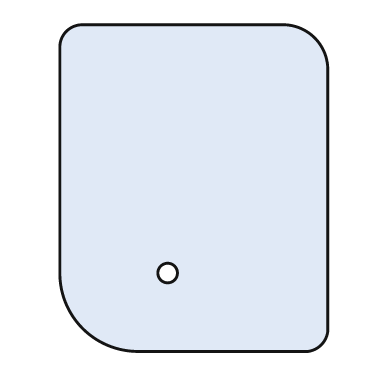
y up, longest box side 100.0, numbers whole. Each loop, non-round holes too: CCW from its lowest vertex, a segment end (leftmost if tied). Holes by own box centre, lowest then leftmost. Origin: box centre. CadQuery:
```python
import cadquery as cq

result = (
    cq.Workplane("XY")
    .moveTo(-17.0, -50.0)
    .lineTo(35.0, -50.0)
    .threePointArc((39.0, -48.0), (41.0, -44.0))
    .lineTo(41.0, 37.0)
    .threePointArc((37.0, 46.0), (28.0, 50.0))
    .lineTo(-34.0, 50.0)
    .threePointArc((-39.0, 48.0), (-41.0, 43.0))
    .lineTo(-41.0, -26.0)
    .threePointArc((-34.0, -43.0), (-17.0, -50.0))
    .close()
    .moveTo(-8.0, -26.0)
    .circle(3.0)
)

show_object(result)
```